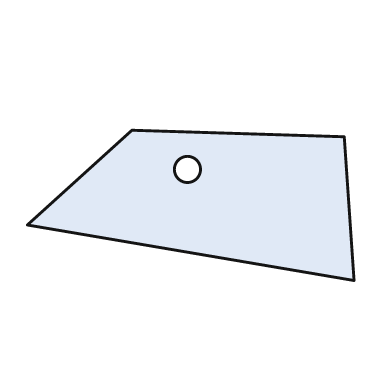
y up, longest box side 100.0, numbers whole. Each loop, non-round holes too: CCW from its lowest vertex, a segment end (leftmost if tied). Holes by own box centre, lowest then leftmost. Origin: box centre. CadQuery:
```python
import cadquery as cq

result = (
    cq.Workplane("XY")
    .moveTo(50.0, -23.0)
    .lineTo(47.0, 21.0)
    .lineTo(-18.0, 23.0)
    .lineTo(-50.0, -6.0)
    .close()
    .moveTo(-1.0, 11.0)
    .circle(4.0)
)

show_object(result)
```